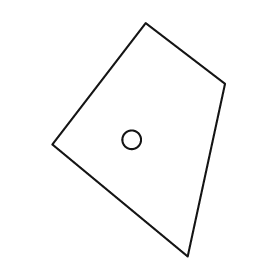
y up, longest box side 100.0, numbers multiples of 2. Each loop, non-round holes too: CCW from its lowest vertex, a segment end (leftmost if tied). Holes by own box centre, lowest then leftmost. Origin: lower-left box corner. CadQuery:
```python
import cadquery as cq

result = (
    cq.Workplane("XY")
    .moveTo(58.0, 0.0)
    .lineTo(74.0, 74.0)
    .lineTo(40.0, 100.0)
    .lineTo(0.0, 48.0)
    .close()
    .moveTo(34.0, 50.0)
    .circle(4.0)
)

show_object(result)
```